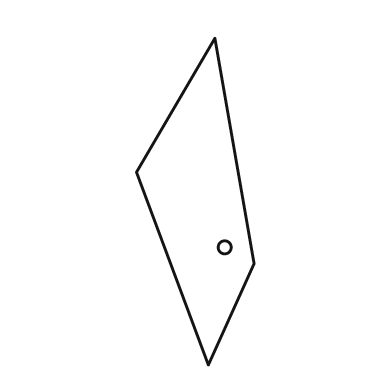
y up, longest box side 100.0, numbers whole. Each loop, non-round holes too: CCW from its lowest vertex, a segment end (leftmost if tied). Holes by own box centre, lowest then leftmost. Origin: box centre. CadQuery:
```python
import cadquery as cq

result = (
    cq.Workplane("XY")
    .moveTo(4.0, -50.0)
    .lineTo(18.0, -19.0)
    .lineTo(6.0, 50.0)
    .lineTo(-18.0, 9.0)
    .close()
    .moveTo(9.0, -14.0)
    .circle(2.0)
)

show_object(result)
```